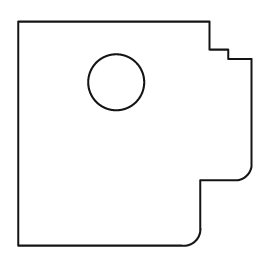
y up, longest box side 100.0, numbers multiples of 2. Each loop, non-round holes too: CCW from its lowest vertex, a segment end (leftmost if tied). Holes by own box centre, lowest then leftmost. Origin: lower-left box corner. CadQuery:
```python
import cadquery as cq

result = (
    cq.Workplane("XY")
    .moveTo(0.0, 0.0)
    .lineTo(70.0, 0.0)
    .threePointArc((76.0, 2.0), (78.0, 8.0))
    .lineTo(78.0, 28.0)
    .lineTo(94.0, 28.0)
    .threePointArc((98.0, 30.0), (100.0, 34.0))
    .lineTo(100.0, 80.0)
    .lineTo(90.0, 80.0)
    .lineTo(90.0, 84.0)
    .lineTo(82.0, 84.0)
    .lineTo(82.0, 96.0)
    .lineTo(0.0, 96.0)
    .close()
    .moveTo(42.0, 70.0)
    .circle(12.0)
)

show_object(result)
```